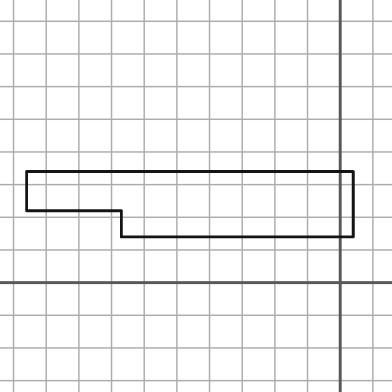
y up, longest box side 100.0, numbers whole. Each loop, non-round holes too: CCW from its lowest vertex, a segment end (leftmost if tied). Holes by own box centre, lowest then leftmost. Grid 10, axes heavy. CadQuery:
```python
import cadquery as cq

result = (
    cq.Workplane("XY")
    .moveTo(-67.0, 14.0)
    .lineTo(4.0, 14.0)
    .lineTo(4.0, 34.0)
    .lineTo(-96.0, 34.0)
    .lineTo(-96.0, 22.0)
    .lineTo(-67.0, 22.0)
    .close()
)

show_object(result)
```